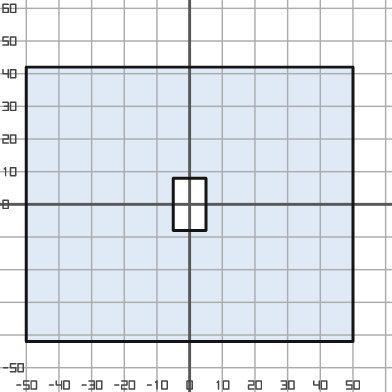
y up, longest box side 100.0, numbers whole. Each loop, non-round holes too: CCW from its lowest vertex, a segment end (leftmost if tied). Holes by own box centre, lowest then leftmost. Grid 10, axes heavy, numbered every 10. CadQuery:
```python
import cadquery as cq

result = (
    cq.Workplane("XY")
    .moveTo(-50.0, -42.0)
    .lineTo(50.0, -42.0)
    .lineTo(50.0, 42.0)
    .lineTo(-50.0, 42.0)
    .close()
    .moveTo(-5.0, -8.0)
    .lineTo(5.0, -8.0)
    .lineTo(5.0, 8.0)
    .lineTo(-5.0, 8.0)
    .close()
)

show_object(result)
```